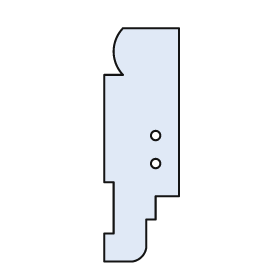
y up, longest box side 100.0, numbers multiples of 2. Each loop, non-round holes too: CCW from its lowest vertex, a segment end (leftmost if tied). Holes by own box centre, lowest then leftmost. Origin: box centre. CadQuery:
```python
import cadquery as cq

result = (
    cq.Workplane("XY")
    .moveTo(-16.0, -50.0)
    .lineTo(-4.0, -50.0)
    .threePointArc((0.0, -48.0), (2.0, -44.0))
    .lineTo(2.0, -32.0)
    .lineTo(6.0, -32.0)
    .lineTo(6.0, -22.0)
    .lineTo(16.0, -22.0)
    .lineTo(16.0, 50.0)
    .lineTo(-8.0, 50.0)
    .threePointArc((-12.0, 40.0), (-8.0, 30.0))
    .lineTo(-16.0, 30.0)
    .lineTo(-16.0, -16.0)
    .lineTo(-12.0, -16.0)
    .lineTo(-12.0, -38.0)
    .lineTo(-16.0, -38.0)
    .close()
    .moveTo(6.0, -8.0)
    .circle(2.0)
    .moveTo(6.0, 4.0)
    .circle(2.0)
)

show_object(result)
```